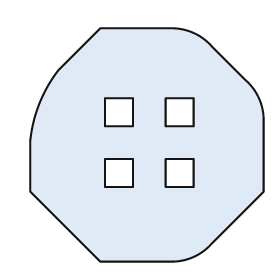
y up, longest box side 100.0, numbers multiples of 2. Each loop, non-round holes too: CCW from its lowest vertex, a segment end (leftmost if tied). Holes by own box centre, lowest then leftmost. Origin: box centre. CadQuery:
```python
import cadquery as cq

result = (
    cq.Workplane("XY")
    .moveTo(-20.0, -50.0)
    .lineTo(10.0, -50.0)
    .threePointArc((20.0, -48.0), (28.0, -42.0))
    .lineTo(50.0, -20.0)
    .lineTo(50.0, 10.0)
    .threePointArc((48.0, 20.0), (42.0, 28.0))
    .lineTo(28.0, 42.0)
    .threePointArc((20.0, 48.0), (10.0, 50.0))
    .lineTo(-20.0, 50.0)
    .lineTo(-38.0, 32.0)
    .threePointArc((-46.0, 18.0), (-50.0, 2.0))
    .lineTo(-50.0, -20.0)
    .close()
    .moveTo(-18.0, -18.0)
    .lineTo(-6.0, -18.0)
    .lineTo(-6.0, -6.0)
    .lineTo(-18.0, -6.0)
    .close()
    .moveTo(8.0, -18.0)
    .lineTo(20.0, -18.0)
    .lineTo(20.0, -6.0)
    .lineTo(8.0, -6.0)
    .close()
    .moveTo(-18.0, 8.0)
    .lineTo(-6.0, 8.0)
    .lineTo(-6.0, 20.0)
    .lineTo(-18.0, 20.0)
    .close()
    .moveTo(8.0, 8.0)
    .lineTo(20.0, 8.0)
    .lineTo(20.0, 20.0)
    .lineTo(8.0, 20.0)
    .close()
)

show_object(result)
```